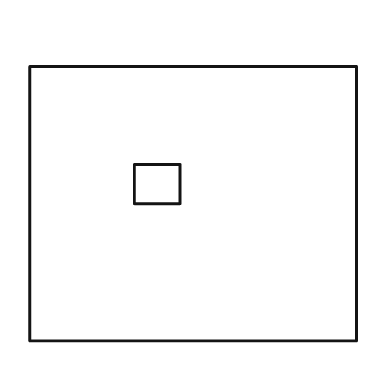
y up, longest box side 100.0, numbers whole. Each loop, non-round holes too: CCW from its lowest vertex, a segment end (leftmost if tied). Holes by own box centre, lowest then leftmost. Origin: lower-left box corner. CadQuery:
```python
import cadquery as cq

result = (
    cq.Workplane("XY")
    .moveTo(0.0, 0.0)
    .lineTo(100.0, 0.0)
    .lineTo(100.0, 84.0)
    .lineTo(0.0, 84.0)
    .close()
    .moveTo(32.0, 42.0)
    .lineTo(46.0, 42.0)
    .lineTo(46.0, 54.0)
    .lineTo(32.0, 54.0)
    .close()
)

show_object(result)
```